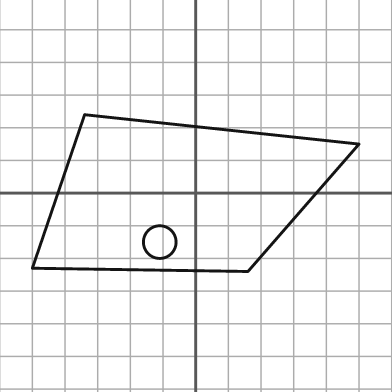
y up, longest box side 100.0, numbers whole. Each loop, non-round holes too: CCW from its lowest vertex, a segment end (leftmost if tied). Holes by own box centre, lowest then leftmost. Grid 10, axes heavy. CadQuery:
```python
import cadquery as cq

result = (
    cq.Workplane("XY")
    .moveTo(16.0, -24.0)
    .lineTo(50.0, 15.0)
    .lineTo(-34.0, 24.0)
    .lineTo(-50.0, -23.0)
    .close()
    .moveTo(-11.0, -15.0)
    .circle(5.0)
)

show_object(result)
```